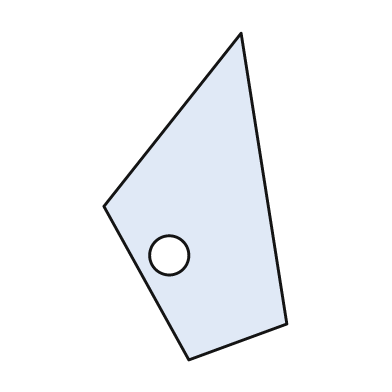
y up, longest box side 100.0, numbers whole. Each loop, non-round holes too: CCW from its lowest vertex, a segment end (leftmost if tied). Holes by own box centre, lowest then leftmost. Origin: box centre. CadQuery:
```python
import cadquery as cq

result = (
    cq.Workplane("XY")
    .moveTo(-2.0, -50.0)
    .lineTo(28.0, -39.0)
    .lineTo(14.0, 50.0)
    .lineTo(-28.0, -3.0)
    .close()
    .moveTo(-8.0, -18.0)
    .circle(6.0)
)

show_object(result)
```